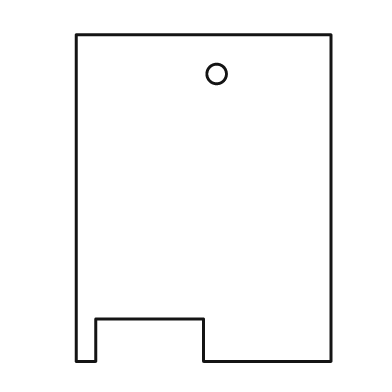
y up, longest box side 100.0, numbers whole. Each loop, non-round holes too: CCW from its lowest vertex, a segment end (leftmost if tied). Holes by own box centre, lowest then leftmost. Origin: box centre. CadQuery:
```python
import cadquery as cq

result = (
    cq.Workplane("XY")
    .moveTo(-39.0, -50.0)
    .lineTo(-33.0, -50.0)
    .lineTo(-33.0, -37.0)
    .lineTo(0.0, -37.0)
    .lineTo(0.0, -50.0)
    .lineTo(39.0, -50.0)
    .lineTo(39.0, 50.0)
    .lineTo(-39.0, 50.0)
    .close()
    .moveTo(4.0, 38.0)
    .circle(3.0)
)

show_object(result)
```